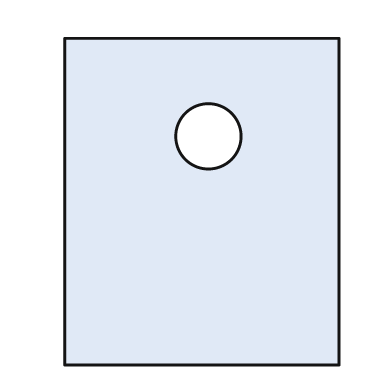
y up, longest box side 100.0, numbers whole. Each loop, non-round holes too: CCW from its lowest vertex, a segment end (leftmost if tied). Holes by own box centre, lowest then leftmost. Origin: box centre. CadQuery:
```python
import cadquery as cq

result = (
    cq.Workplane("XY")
    .moveTo(-42.0, -50.0)
    .lineTo(42.0, -50.0)
    .lineTo(42.0, 50.0)
    .lineTo(-42.0, 50.0)
    .close()
    .moveTo(2.0, 20.0)
    .circle(10.0)
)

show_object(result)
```